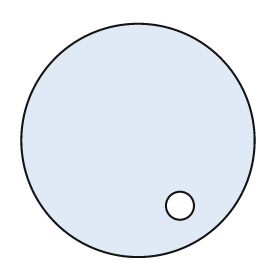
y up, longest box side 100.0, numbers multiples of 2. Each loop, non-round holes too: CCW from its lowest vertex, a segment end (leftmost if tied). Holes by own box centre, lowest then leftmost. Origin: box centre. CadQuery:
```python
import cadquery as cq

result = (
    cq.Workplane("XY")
    .moveTo(0.0, 0.0)
    .circle(50.0)
    .moveTo(18.0, -28.0)
    .circle(6.0)
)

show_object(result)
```